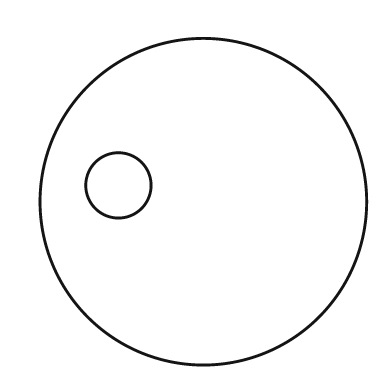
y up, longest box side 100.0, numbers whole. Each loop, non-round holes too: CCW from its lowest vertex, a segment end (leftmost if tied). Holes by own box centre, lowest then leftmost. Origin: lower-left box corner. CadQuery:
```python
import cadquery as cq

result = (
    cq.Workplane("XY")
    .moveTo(50.0, 50.0)
    .circle(50.0)
    .moveTo(24.0, 55.0)
    .circle(10.0)
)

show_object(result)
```